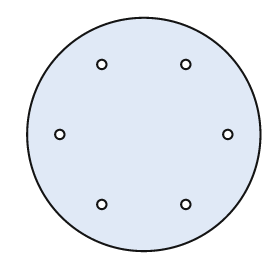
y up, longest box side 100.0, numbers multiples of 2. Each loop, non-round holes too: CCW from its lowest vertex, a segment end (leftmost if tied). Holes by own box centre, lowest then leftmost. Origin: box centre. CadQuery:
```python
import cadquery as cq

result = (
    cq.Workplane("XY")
    .moveTo(0.0, 0.0)
    .circle(50.0)
    .moveTo(-18.0, -30.0)
    .circle(2.0)
    .moveTo(18.0, -30.0)
    .circle(2.0)
    .moveTo(-36.0, 0.0)
    .circle(2.0)
    .moveTo(36.0, 0.0)
    .circle(2.0)
    .moveTo(-18.0, 30.0)
    .circle(2.0)
    .moveTo(18.0, 30.0)
    .circle(2.0)
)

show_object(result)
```